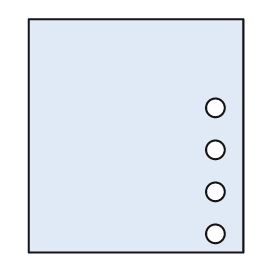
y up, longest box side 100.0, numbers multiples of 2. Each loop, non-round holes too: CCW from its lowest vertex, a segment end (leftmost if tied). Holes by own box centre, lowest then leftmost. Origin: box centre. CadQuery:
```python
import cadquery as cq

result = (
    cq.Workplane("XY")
    .moveTo(-46.0, -50.0)
    .lineTo(46.0, -50.0)
    .lineTo(46.0, 50.0)
    .lineTo(-46.0, 50.0)
    .close()
    .moveTo(34.0, -42.0)
    .circle(4.0)
    .moveTo(34.0, -24.0)
    .circle(4.0)
    .moveTo(34.0, -6.0)
    .circle(4.0)
    .moveTo(34.0, 12.0)
    .circle(4.0)
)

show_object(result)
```